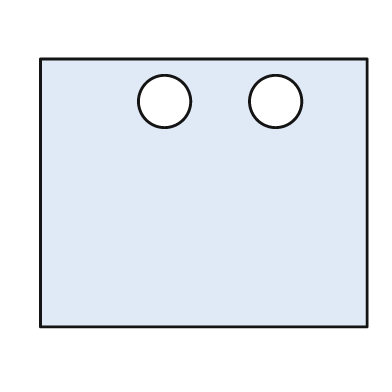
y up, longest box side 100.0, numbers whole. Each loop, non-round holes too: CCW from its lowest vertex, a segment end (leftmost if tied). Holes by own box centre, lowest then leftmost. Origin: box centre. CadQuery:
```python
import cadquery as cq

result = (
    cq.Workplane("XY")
    .moveTo(-50.0, -41.0)
    .lineTo(50.0, -41.0)
    .lineTo(50.0, 41.0)
    .lineTo(-50.0, 41.0)
    .close()
    .moveTo(-12.0, 28.0)
    .circle(8.0)
    .moveTo(22.0, 28.0)
    .circle(8.0)
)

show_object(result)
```